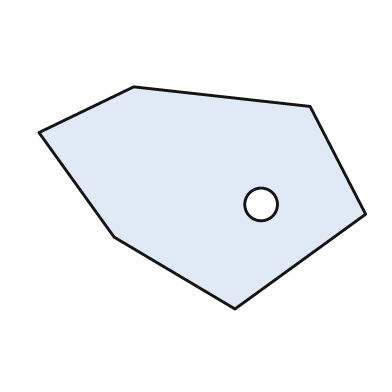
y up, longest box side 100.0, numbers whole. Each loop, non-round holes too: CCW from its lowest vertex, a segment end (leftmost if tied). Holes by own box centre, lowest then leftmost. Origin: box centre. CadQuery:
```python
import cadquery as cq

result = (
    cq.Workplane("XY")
    .moveTo(10.0, -34.0)
    .lineTo(50.0, -5.0)
    .lineTo(33.0, 28.0)
    .lineTo(-21.0, 34.0)
    .lineTo(-50.0, 20.0)
    .lineTo(-27.0, -12.0)
    .close()
    .moveTo(18.0, -2.0)
    .circle(5.0)
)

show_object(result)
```